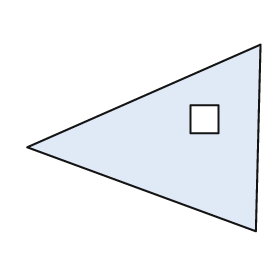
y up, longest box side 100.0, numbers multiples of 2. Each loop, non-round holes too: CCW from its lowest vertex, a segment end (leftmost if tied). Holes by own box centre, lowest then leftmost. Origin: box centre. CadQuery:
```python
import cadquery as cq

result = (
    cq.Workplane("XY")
    .moveTo(48.0, -40.0)
    .lineTo(50.0, 40.0)
    .lineTo(-50.0, -4.0)
    .close()
    .moveTo(20.0, 2.0)
    .lineTo(32.0, 2.0)
    .lineTo(32.0, 14.0)
    .lineTo(20.0, 14.0)
    .close()
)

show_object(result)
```